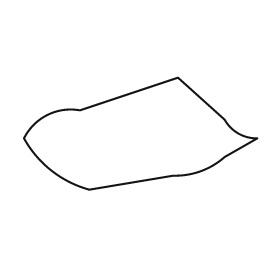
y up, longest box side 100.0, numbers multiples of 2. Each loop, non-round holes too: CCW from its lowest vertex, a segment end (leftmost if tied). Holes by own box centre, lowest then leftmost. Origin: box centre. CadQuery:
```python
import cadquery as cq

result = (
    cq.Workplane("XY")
    .moveTo(-22.0, -24.0)
    .lineTo(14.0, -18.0)
    .threePointArc((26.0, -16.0), (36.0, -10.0))
    .lineTo(50.0, -2.0)
    .threePointArc((42.0, 0.0), (36.0, 6.0))
    .lineTo(16.0, 24.0)
    .lineTo(-26.0, 10.0)
    .threePointArc((-40.0, 8.0), (-50.0, -2.0))
    .threePointArc((-38.0, -16.0), (-22.0, -24.0))
    .close()
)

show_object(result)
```